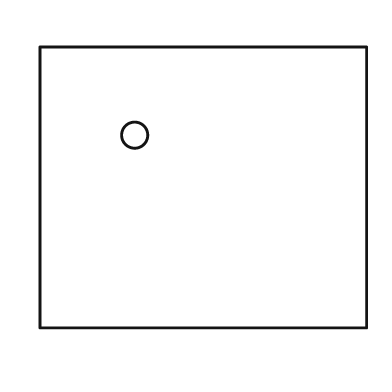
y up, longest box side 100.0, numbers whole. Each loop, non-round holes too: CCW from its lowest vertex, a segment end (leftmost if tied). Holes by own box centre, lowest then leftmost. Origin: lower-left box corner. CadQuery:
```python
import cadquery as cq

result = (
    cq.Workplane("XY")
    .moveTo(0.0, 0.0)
    .lineTo(100.0, 0.0)
    .lineTo(100.0, 86.0)
    .lineTo(0.0, 86.0)
    .close()
    .moveTo(29.0, 59.0)
    .circle(4.0)
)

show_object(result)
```